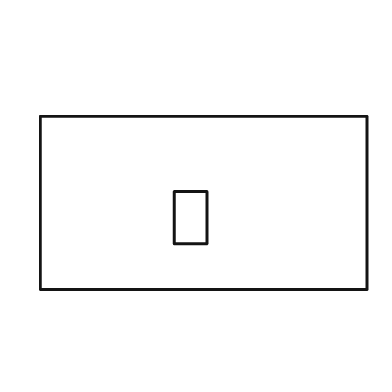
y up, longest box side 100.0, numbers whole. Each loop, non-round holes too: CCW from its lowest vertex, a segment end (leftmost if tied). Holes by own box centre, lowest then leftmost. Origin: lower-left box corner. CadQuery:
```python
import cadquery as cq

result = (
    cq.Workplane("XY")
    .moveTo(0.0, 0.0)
    .lineTo(100.0, 0.0)
    .lineTo(100.0, 53.0)
    .lineTo(0.0, 53.0)
    .close()
    .moveTo(41.0, 14.0)
    .lineTo(51.0, 14.0)
    .lineTo(51.0, 30.0)
    .lineTo(41.0, 30.0)
    .close()
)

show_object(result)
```